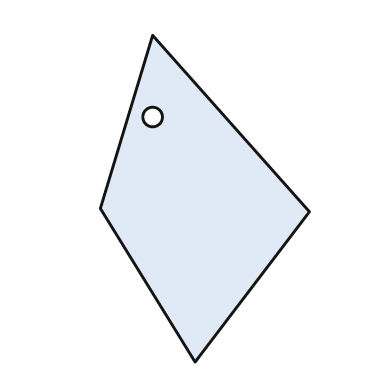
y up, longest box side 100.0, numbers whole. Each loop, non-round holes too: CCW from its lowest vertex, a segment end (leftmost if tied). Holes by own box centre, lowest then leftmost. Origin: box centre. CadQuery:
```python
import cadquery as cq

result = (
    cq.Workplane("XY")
    .moveTo(-3.0, -50.0)
    .lineTo(32.0, -4.0)
    .lineTo(-16.0, 50.0)
    .lineTo(-32.0, -3.0)
    .close()
    .moveTo(-16.0, 25.0)
    .circle(3.0)
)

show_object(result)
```